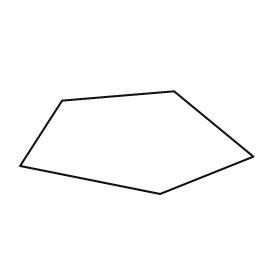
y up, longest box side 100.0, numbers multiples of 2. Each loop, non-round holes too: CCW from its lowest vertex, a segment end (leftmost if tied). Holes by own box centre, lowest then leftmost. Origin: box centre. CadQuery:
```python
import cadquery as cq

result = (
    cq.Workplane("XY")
    .moveTo(10.0, -22.0)
    .lineTo(50.0, -6.0)
    .lineTo(16.0, 22.0)
    .lineTo(-32.0, 18.0)
    .lineTo(-50.0, -10.0)
    .close()
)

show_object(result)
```